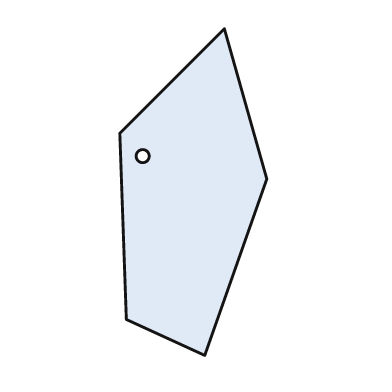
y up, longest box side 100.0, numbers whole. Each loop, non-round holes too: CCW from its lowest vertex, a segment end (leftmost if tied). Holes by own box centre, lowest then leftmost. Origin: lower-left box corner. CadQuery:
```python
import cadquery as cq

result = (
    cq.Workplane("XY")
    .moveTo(26.0, 0.0)
    .lineTo(45.0, 54.0)
    .lineTo(32.0, 100.0)
    .lineTo(0.0, 68.0)
    .lineTo(2.0, 11.0)
    .close()
    .moveTo(7.0, 61.0)
    .circle(2.0)
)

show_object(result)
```